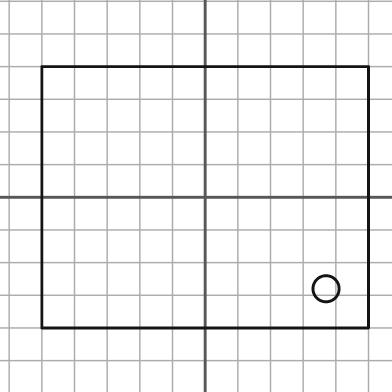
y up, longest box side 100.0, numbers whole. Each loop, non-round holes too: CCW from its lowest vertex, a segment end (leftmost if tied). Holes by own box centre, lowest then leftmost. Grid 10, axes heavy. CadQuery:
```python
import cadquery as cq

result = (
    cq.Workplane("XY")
    .moveTo(-50.0, -40.0)
    .lineTo(50.0, -40.0)
    .lineTo(50.0, 40.0)
    .lineTo(-50.0, 40.0)
    .close()
    .moveTo(37.0, -28.0)
    .circle(4.0)
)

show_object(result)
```